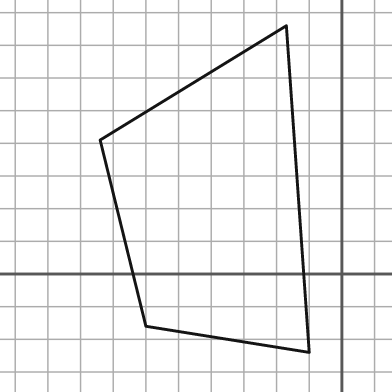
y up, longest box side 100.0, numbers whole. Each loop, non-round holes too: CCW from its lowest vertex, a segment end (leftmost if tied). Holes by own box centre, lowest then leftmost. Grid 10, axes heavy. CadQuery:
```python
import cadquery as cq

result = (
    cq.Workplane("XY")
    .moveTo(-10.0, -24.0)
    .lineTo(-17.0, 76.0)
    .lineTo(-74.0, 41.0)
    .lineTo(-60.0, -16.0)
    .close()
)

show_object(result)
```